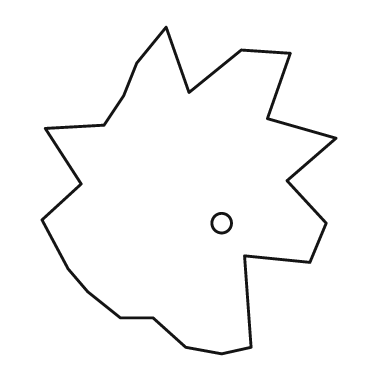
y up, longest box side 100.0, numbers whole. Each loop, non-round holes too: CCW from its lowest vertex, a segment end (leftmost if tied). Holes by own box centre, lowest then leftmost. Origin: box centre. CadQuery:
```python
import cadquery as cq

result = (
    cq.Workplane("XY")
    .moveTo(10.0, -50.0)
    .lineTo(19.0, -48.0)
    .lineTo(17.0, -20.0)
    .lineTo(37.0, -22.0)
    .lineTo(42.0, -10.0)
    .lineTo(30.0, 3.0)
    .lineTo(45.0, 16.0)
    .lineTo(24.0, 22.0)
    .lineTo(31.0, 42.0)
    .lineTo(16.0, 43.0)
    .lineTo(0.0, 30.0)
    .lineTo(-7.0, 50.0)
    .lineTo(-16.0, 39.0)
    .lineTo(-20.0, 29.0)
    .lineTo(-26.0, 20.0)
    .lineTo(-44.0, 19.0)
    .lineTo(-33.0, 2.0)
    .lineTo(-45.0, -9.0)
    .lineTo(-37.0, -24.0)
    .lineTo(-31.0, -31.0)
    .lineTo(-21.0, -39.0)
    .lineTo(-11.0, -39.0)
    .lineTo(-1.0, -48.0)
    .close()
    .moveTo(10.0, -10.0)
    .circle(3.0)
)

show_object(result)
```